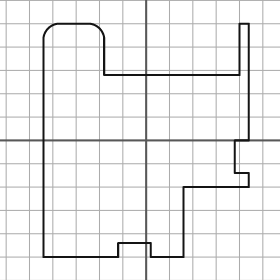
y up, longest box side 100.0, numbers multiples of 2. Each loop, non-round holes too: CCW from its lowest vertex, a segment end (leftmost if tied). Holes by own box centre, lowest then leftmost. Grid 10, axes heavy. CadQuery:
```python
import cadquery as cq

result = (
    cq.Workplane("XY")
    .moveTo(-44.0, -50.0)
    .lineTo(-12.0, -50.0)
    .lineTo(-12.0, -44.0)
    .lineTo(2.0, -44.0)
    .lineTo(2.0, -50.0)
    .lineTo(16.0, -50.0)
    .lineTo(16.0, -20.0)
    .lineTo(44.0, -20.0)
    .lineTo(44.0, -14.0)
    .lineTo(38.0, -14.0)
    .lineTo(38.0, 0.0)
    .lineTo(44.0, 0.0)
    .lineTo(44.0, 50.0)
    .lineTo(40.0, 50.0)
    .lineTo(40.0, 28.0)
    .lineTo(-18.0, 28.0)
    .lineTo(-18.0, 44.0)
    .threePointArc((-20.0, 48.0), (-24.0, 50.0))
    .lineTo(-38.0, 50.0)
    .threePointArc((-42.0, 48.0), (-44.0, 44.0))
    .close()
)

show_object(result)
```